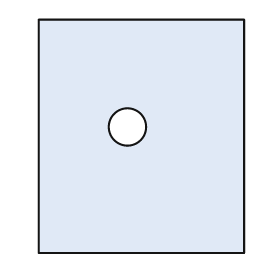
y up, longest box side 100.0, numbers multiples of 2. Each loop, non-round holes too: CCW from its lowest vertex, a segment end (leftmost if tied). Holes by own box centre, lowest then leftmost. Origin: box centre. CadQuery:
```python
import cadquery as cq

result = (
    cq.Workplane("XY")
    .moveTo(-44.0, -50.0)
    .lineTo(44.0, -50.0)
    .lineTo(44.0, 50.0)
    .lineTo(-44.0, 50.0)
    .close()
    .moveTo(-6.0, 4.0)
    .circle(8.0)
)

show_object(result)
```